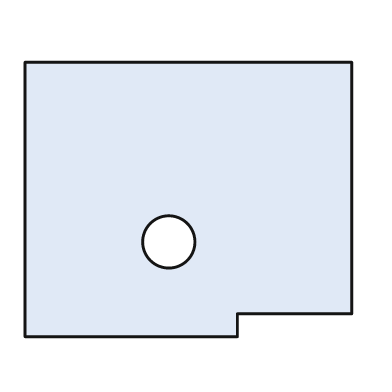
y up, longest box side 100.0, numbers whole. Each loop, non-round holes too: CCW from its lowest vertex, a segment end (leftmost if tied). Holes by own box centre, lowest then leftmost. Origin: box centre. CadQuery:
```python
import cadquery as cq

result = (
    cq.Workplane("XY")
    .moveTo(-50.0, -42.0)
    .lineTo(15.0, -42.0)
    .lineTo(15.0, -35.0)
    .lineTo(50.0, -35.0)
    .lineTo(50.0, 42.0)
    .lineTo(-50.0, 42.0)
    .close()
    .moveTo(-6.0, -13.0)
    .circle(8.0)
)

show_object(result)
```